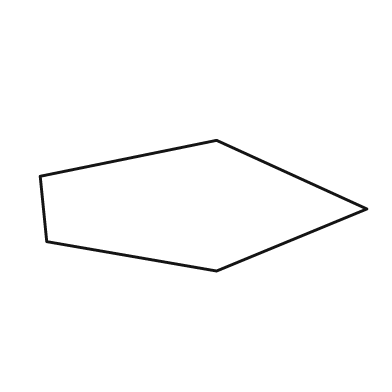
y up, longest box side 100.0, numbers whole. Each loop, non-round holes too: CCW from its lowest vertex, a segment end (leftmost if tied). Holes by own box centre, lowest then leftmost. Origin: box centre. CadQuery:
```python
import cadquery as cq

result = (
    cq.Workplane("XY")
    .moveTo(4.0, -20.0)
    .lineTo(50.0, -1.0)
    .lineTo(4.0, 20.0)
    .lineTo(-50.0, 9.0)
    .lineTo(-48.0, -11.0)
    .close()
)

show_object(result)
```